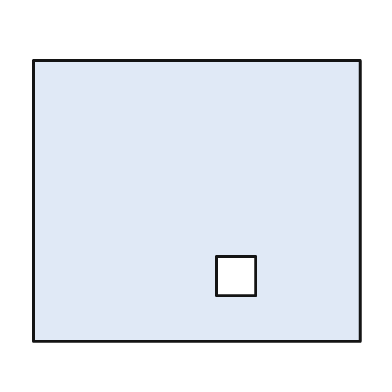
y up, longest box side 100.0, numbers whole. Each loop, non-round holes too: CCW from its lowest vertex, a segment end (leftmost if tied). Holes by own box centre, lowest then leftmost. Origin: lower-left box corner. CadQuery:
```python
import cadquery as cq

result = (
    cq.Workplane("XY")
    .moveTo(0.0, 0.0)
    .lineTo(100.0, 0.0)
    .lineTo(100.0, 86.0)
    .lineTo(0.0, 86.0)
    .close()
    .moveTo(56.0, 14.0)
    .lineTo(68.0, 14.0)
    .lineTo(68.0, 26.0)
    .lineTo(56.0, 26.0)
    .close()
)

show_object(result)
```